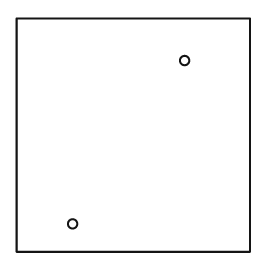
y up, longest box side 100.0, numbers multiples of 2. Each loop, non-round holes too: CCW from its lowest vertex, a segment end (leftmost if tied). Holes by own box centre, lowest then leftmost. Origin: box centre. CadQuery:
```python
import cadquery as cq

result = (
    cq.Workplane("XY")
    .moveTo(-50.0, -50.0)
    .lineTo(50.0, -50.0)
    .lineTo(50.0, 50.0)
    .lineTo(-50.0, 50.0)
    .close()
    .moveTo(-26.0, -38.0)
    .circle(2.0)
    .moveTo(22.0, 32.0)
    .circle(2.0)
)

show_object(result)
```